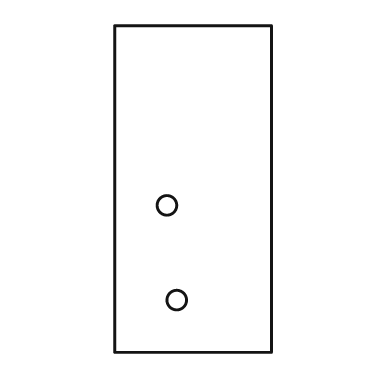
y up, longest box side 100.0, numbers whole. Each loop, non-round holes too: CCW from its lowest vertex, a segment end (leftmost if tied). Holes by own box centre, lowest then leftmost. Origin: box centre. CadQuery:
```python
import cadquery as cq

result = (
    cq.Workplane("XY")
    .moveTo(-24.0, -50.0)
    .lineTo(24.0, -50.0)
    .lineTo(24.0, 50.0)
    .lineTo(-24.0, 50.0)
    .close()
    .moveTo(-5.0, -34.0)
    .circle(3.0)
    .moveTo(-8.0, -5.0)
    .circle(3.0)
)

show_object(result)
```